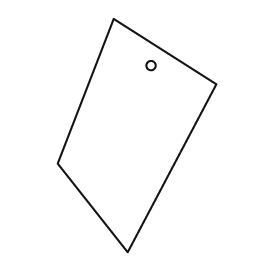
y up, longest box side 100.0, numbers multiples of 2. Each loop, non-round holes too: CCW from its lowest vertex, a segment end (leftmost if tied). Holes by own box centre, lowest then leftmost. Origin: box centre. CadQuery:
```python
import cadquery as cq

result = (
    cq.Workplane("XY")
    .moveTo(-4.0, -50.0)
    .lineTo(34.0, 22.0)
    .lineTo(-10.0, 50.0)
    .lineTo(-34.0, -12.0)
    .close()
    .moveTo(6.0, 30.0)
    .circle(2.0)
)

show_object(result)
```